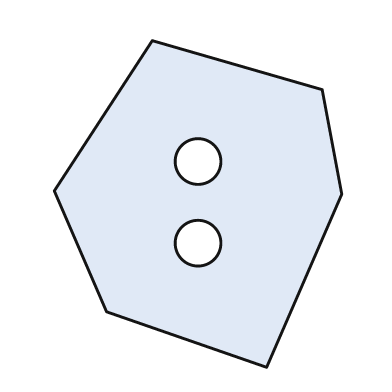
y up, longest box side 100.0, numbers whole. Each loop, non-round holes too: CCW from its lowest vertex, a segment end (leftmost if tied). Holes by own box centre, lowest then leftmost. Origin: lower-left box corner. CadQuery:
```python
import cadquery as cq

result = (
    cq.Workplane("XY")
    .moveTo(65.0, 0.0)
    .lineTo(88.0, 53.0)
    .lineTo(82.0, 85.0)
    .lineTo(30.0, 100.0)
    .lineTo(0.0, 54.0)
    .lineTo(16.0, 17.0)
    .close()
    .moveTo(44.0, 38.0)
    .circle(7.0)
    .moveTo(44.0, 63.0)
    .circle(7.0)
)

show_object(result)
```